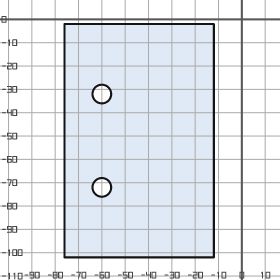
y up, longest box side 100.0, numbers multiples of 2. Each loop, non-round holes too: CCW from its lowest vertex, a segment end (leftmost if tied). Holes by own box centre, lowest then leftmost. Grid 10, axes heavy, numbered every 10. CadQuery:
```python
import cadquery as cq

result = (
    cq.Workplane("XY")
    .moveTo(-76.0, -102.0)
    .lineTo(-12.0, -102.0)
    .lineTo(-12.0, -2.0)
    .lineTo(-76.0, -2.0)
    .close()
    .moveTo(-60.0, -72.0)
    .circle(4.0)
    .moveTo(-60.0, -32.0)
    .circle(4.0)
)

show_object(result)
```